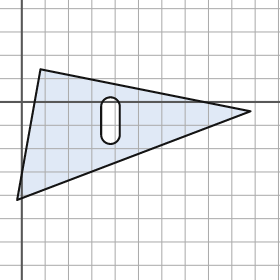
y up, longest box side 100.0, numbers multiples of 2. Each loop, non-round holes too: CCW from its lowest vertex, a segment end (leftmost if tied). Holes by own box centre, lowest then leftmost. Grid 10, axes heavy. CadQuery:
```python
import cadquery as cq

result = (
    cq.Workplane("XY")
    .moveTo(-2.0, -42.0)
    .lineTo(98.0, -4.0)
    .lineTo(8.0, 14.0)
    .close()
    .moveTo(34.0, -14.0)
    .threePointArc((38.0, -18.0), (42.0, -14.0))
    .lineTo(42.0, -2.0)
    .threePointArc((38.0, 2.0), (34.0, -2.0))
    .close()
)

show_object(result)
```